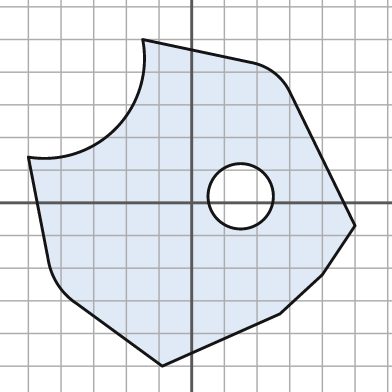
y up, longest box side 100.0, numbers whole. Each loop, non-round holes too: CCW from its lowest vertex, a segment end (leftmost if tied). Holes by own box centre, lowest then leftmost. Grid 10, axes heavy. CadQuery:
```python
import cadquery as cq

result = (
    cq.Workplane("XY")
    .moveTo(-9.0, -50.0)
    .lineTo(27.0, -34.0)
    .lineTo(40.0, -22.0)
    .lineTo(50.0, -7.0)
    .lineTo(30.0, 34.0)
    .threePointArc((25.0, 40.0), (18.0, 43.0))
    .lineTo(-15.0, 50.0)
    .threePointArc((-23.0, 23.0), (-50.0, 14.0))
    .lineTo(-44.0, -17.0)
    .threePointArc((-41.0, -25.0), (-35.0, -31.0))
    .close()
    .moveTo(15.0, 2.0)
    .circle(10.0)
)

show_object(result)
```